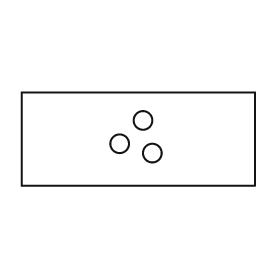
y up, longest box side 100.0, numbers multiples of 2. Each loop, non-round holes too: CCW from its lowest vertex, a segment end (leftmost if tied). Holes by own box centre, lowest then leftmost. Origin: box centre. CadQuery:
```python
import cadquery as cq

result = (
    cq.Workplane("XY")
    .moveTo(-50.0, -20.0)
    .lineTo(50.0, -20.0)
    .lineTo(50.0, 20.0)
    .lineTo(-50.0, 20.0)
    .close()
    .moveTo(6.0, -6.0)
    .circle(4.0)
    .moveTo(-8.0, -2.0)
    .circle(4.0)
    .moveTo(2.0, 8.0)
    .circle(4.0)
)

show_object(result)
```